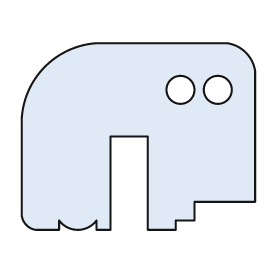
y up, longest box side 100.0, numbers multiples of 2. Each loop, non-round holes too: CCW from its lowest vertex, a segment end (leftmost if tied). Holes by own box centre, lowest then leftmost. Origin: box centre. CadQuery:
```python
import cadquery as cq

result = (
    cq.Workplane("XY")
    .moveTo(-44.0, -40.0)
    .lineTo(-34.0, -40.0)
    .lineTo(-34.0, -36.0)
    .threePointArc((-26.0, -40.0), (-18.0, -36.0))
    .lineTo(-18.0, -40.0)
    .lineTo(-12.0, -40.0)
    .lineTo(-12.0, 0.0)
    .lineTo(4.0, 0.0)
    .lineTo(4.0, -40.0)
    .lineTo(16.0, -40.0)
    .lineTo(16.0, -36.0)
    .lineTo(24.0, -36.0)
    .lineTo(24.0, -28.0)
    .lineTo(50.0, -28.0)
    .lineTo(50.0, 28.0)
    .threePointArc((46.0, 36.0), (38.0, 40.0))
    .lineTo(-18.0, 40.0)
    .threePointArc((-40.0, 30.0), (-50.0, 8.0))
    .lineTo(-50.0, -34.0)
    .threePointArc((-48.0, -38.0), (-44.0, -40.0))
    .close()
    .moveTo(18.0, 20.0)
    .circle(6.0)
    .moveTo(34.0, 20.0)
    .circle(6.0)
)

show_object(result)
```